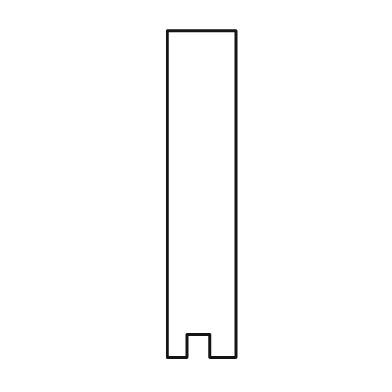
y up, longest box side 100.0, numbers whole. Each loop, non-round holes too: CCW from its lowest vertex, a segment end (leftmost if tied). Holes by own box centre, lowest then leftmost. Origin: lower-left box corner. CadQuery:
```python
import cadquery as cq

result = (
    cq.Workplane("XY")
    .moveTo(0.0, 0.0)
    .lineTo(6.0, 0.0)
    .lineTo(6.0, 7.0)
    .lineTo(13.0, 7.0)
    .lineTo(13.0, 0.0)
    .lineTo(21.0, 0.0)
    .lineTo(21.0, 100.0)
    .lineTo(0.0, 100.0)
    .close()
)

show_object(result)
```